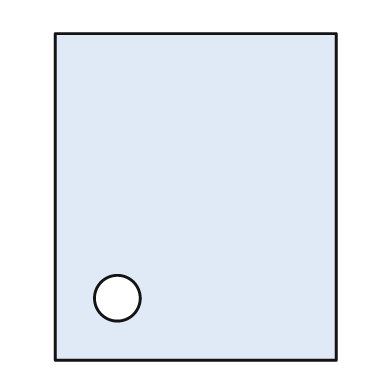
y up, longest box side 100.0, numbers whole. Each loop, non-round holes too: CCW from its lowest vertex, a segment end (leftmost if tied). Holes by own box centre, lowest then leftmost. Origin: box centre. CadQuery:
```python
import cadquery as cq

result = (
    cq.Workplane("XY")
    .moveTo(-43.0, -50.0)
    .lineTo(43.0, -50.0)
    .lineTo(43.0, 50.0)
    .lineTo(-43.0, 50.0)
    .close()
    .moveTo(-24.0, -31.0)
    .circle(7.0)
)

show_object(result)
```